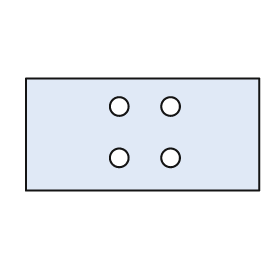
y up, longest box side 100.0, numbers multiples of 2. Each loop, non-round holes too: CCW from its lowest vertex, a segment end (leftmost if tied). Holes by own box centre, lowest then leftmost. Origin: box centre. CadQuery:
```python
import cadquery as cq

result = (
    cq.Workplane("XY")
    .moveTo(-50.0, -24.0)
    .lineTo(50.0, -24.0)
    .lineTo(50.0, 24.0)
    .lineTo(-50.0, 24.0)
    .close()
    .moveTo(-10.0, -10.0)
    .circle(4.0)
    .moveTo(12.0, -10.0)
    .circle(4.0)
    .moveTo(-10.0, 12.0)
    .circle(4.0)
    .moveTo(12.0, 12.0)
    .circle(4.0)
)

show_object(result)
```